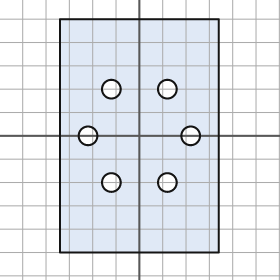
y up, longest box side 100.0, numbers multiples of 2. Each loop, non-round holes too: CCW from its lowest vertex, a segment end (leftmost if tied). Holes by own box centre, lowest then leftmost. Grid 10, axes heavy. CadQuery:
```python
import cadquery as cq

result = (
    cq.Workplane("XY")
    .moveTo(-34.0, -50.0)
    .lineTo(34.0, -50.0)
    .lineTo(34.0, 50.0)
    .lineTo(-34.0, 50.0)
    .close()
    .moveTo(-12.0, -20.0)
    .circle(4.0)
    .moveTo(12.0, -20.0)
    .circle(4.0)
    .moveTo(-22.0, 0.0)
    .circle(4.0)
    .moveTo(22.0, 0.0)
    .circle(4.0)
    .moveTo(-12.0, 20.0)
    .circle(4.0)
    .moveTo(12.0, 20.0)
    .circle(4.0)
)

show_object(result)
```